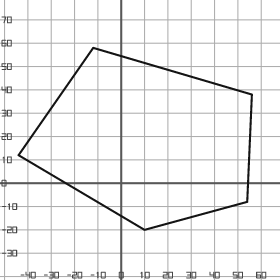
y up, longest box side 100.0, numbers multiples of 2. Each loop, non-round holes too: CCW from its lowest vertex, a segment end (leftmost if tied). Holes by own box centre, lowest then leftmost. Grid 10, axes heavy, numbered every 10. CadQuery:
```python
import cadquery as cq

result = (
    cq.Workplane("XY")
    .moveTo(10.0, -20.0)
    .lineTo(54.0, -8.0)
    .lineTo(56.0, 38.0)
    .lineTo(-12.0, 58.0)
    .lineTo(-44.0, 12.0)
    .close()
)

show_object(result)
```